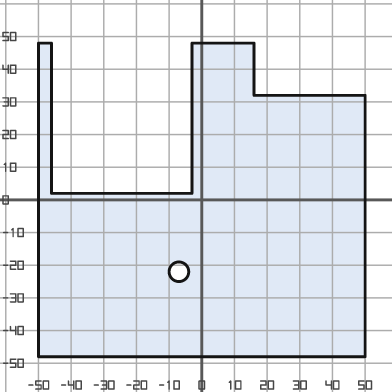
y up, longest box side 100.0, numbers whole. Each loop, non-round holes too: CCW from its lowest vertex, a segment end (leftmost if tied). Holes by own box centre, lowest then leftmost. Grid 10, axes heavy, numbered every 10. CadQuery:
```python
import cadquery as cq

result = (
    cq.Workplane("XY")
    .moveTo(-50.0, -48.0)
    .lineTo(50.0, -48.0)
    .lineTo(50.0, 32.0)
    .lineTo(16.0, 32.0)
    .lineTo(16.0, 48.0)
    .lineTo(-3.0, 48.0)
    .lineTo(-3.0, 2.0)
    .lineTo(-46.0, 2.0)
    .lineTo(-46.0, 48.0)
    .lineTo(-50.0, 48.0)
    .close()
    .moveTo(-7.0, -22.0)
    .circle(3.0)
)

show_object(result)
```